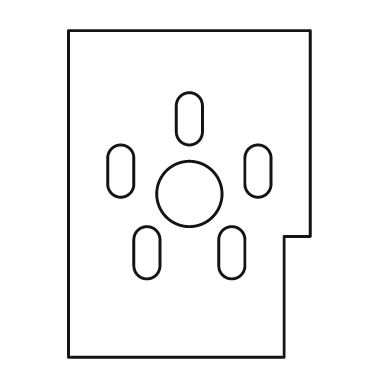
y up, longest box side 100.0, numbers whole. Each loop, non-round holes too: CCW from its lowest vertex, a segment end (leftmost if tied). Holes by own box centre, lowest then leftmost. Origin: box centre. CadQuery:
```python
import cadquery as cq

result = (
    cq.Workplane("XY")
    .moveTo(-37.0, -50.0)
    .lineTo(29.0, -50.0)
    .lineTo(29.0, -13.0)
    .lineTo(37.0, -13.0)
    .lineTo(37.0, 50.0)
    .lineTo(-37.0, 50.0)
    .close()
    .moveTo(-17.0, -22.0)
    .threePointArc((-13.0, -26.0), (-9.0, -22.0))
    .lineTo(-9.0, -14.0)
    .threePointArc((-13.0, -10.0), (-17.0, -14.0))
    .close()
    .moveTo(9.0, -22.0)
    .threePointArc((13.0, -26.0), (17.0, -22.0))
    .lineTo(17.0, -14.0)
    .threePointArc((13.0, -10.0), (9.0, -14.0))
    .close()
    .moveTo(0.0, 0.0)
    .circle(10.0)
    .moveTo(-25.0, 3.0)
    .threePointArc((-21.0, -1.0), (-17.0, 3.0))
    .lineTo(-17.0, 11.0)
    .threePointArc((-21.0, 15.0), (-25.0, 11.0))
    .close()
    .moveTo(17.0, 3.0)
    .threePointArc((21.0, -1.0), (25.0, 3.0))
    .lineTo(25.0, 11.0)
    .threePointArc((21.0, 15.0), (17.0, 11.0))
    .close()
    .moveTo(-4.0, 19.0)
    .threePointArc((0.0, 15.0), (4.0, 19.0))
    .lineTo(4.0, 27.0)
    .threePointArc((0.0, 31.0), (-4.0, 27.0))
    .close()
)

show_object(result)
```